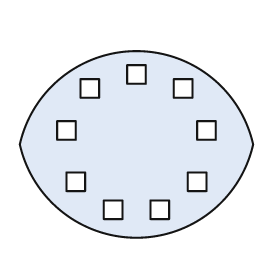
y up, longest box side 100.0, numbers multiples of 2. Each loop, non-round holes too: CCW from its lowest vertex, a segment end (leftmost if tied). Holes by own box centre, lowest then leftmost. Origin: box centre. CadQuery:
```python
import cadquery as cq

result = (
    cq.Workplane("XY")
    .moveTo(-50.0, 0.0)
    .threePointArc((0.0, -40.0), (50.0, 0.0))
    .threePointArc((0.0, 40.0), (-50.0, 0.0))
    .close()
    .moveTo(-14.0, -32.0)
    .lineTo(-6.0, -32.0)
    .lineTo(-6.0, -24.0)
    .lineTo(-14.0, -24.0)
    .close()
    .moveTo(6.0, -32.0)
    .lineTo(14.0, -32.0)
    .lineTo(14.0, -24.0)
    .lineTo(6.0, -24.0)
    .close()
    .moveTo(-30.0, -20.0)
    .lineTo(-22.0, -20.0)
    .lineTo(-22.0, -12.0)
    .lineTo(-30.0, -12.0)
    .close()
    .moveTo(22.0, -20.0)
    .lineTo(30.0, -20.0)
    .lineTo(30.0, -12.0)
    .lineTo(22.0, -12.0)
    .close()
    .moveTo(-34.0, 2.0)
    .lineTo(-26.0, 2.0)
    .lineTo(-26.0, 10.0)
    .lineTo(-34.0, 10.0)
    .close()
    .moveTo(26.0, 2.0)
    .lineTo(34.0, 2.0)
    .lineTo(34.0, 10.0)
    .lineTo(26.0, 10.0)
    .close()
    .moveTo(-24.0, 20.0)
    .lineTo(-16.0, 20.0)
    .lineTo(-16.0, 28.0)
    .lineTo(-24.0, 28.0)
    .close()
    .moveTo(16.0, 20.0)
    .lineTo(24.0, 20.0)
    .lineTo(24.0, 28.0)
    .lineTo(16.0, 28.0)
    .close()
    .moveTo(-4.0, 26.0)
    .lineTo(4.0, 26.0)
    .lineTo(4.0, 34.0)
    .lineTo(-4.0, 34.0)
    .close()
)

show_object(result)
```